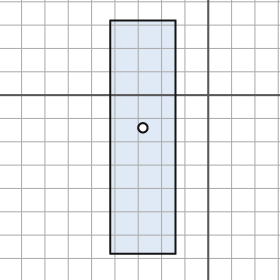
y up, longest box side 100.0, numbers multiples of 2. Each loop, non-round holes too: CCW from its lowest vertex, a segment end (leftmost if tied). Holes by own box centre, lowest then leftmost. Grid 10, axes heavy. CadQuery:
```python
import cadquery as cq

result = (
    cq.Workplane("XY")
    .moveTo(-42.0, -68.0)
    .lineTo(-14.0, -68.0)
    .lineTo(-14.0, 32.0)
    .lineTo(-42.0, 32.0)
    .close()
    .moveTo(-28.0, -14.0)
    .circle(2.0)
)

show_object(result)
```